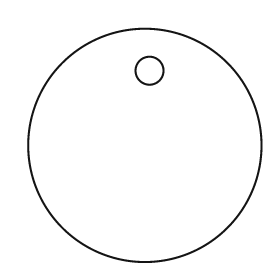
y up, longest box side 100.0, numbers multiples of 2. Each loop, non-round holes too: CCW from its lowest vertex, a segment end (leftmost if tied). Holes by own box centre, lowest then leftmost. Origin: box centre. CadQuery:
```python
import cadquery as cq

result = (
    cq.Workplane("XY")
    .moveTo(0.0, 0.0)
    .circle(50.0)
    .moveTo(2.0, 32.0)
    .circle(6.0)
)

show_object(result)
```